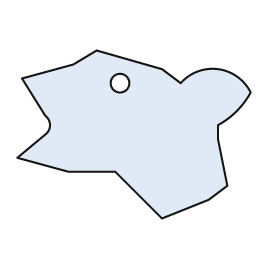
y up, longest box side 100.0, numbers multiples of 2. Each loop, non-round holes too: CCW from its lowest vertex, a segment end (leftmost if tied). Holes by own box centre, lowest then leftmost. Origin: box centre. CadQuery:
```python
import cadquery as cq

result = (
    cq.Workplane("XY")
    .moveTo(12.0, -36.0)
    .lineTo(32.0, -28.0)
    .lineTo(40.0, -22.0)
    .lineTo(36.0, -2.0)
    .lineTo(36.0, 4.0)
    .threePointArc((44.0, 10.0), (50.0, 18.0))
    .threePointArc((36.0, 28.0), (20.0, 22.0))
    .lineTo(12.0, 28.0)
    .lineTo(-16.0, 36.0)
    .lineTo(-26.0, 30.0)
    .lineTo(-48.0, 24.0)
    .lineTo(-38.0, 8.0)
    .threePointArc((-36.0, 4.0), (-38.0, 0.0))
    .lineTo(-50.0, -10.0)
    .lineTo(-28.0, -16.0)
    .lineTo(-8.0, -16.0)
    .close()
    .moveTo(-6.0, 22.0)
    .circle(4.0)
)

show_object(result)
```